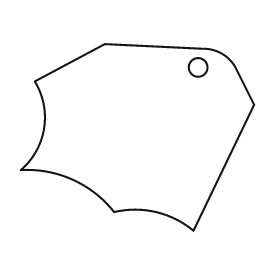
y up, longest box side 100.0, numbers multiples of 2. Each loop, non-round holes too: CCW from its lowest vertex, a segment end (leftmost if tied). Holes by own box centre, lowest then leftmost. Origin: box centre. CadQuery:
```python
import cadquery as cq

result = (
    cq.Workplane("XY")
    .moveTo(24.0, -40.0)
    .lineTo(50.0, 14.0)
    .lineTo(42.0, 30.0)
    .threePointArc((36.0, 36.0), (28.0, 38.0))
    .lineTo(-14.0, 40.0)
    .lineTo(-44.0, 24.0)
    .threePointArc((-40.0, 4.0), (-50.0, -14.0))
    .threePointArc((-28.0, -18.0), (-10.0, -32.0))
    .threePointArc((8.0, -32.0), (24.0, -40.0))
    .close()
    .moveTo(26.0, 30.0)
    .circle(4.0)
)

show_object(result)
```